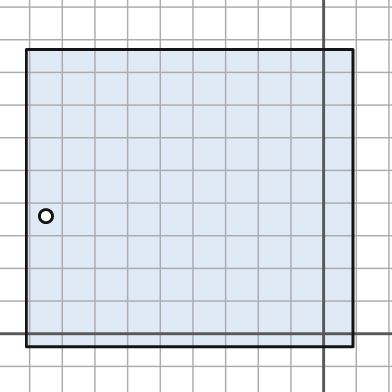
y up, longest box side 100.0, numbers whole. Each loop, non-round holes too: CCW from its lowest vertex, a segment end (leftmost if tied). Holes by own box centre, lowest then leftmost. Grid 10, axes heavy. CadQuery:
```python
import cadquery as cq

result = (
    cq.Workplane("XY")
    .moveTo(-91.0, -4.0)
    .lineTo(9.0, -4.0)
    .lineTo(9.0, 87.0)
    .lineTo(-91.0, 87.0)
    .close()
    .moveTo(-85.0, 36.0)
    .circle(2.0)
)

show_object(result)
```